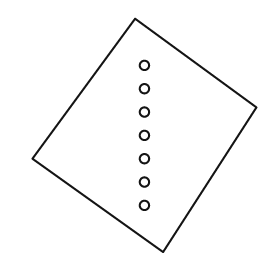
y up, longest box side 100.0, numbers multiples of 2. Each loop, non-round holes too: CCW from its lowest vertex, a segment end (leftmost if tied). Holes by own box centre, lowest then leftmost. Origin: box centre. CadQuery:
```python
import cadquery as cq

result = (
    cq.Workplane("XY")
    .moveTo(8.0, -50.0)
    .lineTo(48.0, 12.0)
    .lineTo(-4.0, 50.0)
    .lineTo(-48.0, -10.0)
    .close()
    .moveTo(0.0, -30.0)
    .circle(2.0)
    .moveTo(0.0, -20.0)
    .circle(2.0)
    .moveTo(0.0, -10.0)
    .circle(2.0)
    .moveTo(0.0, 0.0)
    .circle(2.0)
    .moveTo(0.0, 10.0)
    .circle(2.0)
    .moveTo(0.0, 20.0)
    .circle(2.0)
    .moveTo(0.0, 30.0)
    .circle(2.0)
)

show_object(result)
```